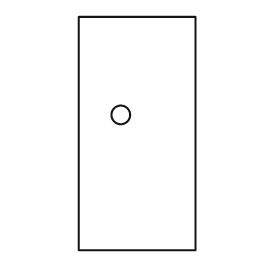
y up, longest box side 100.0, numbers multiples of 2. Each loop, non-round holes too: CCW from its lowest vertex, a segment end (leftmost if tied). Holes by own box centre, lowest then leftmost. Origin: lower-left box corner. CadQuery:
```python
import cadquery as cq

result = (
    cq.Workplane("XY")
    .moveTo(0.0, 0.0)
    .lineTo(50.0, 0.0)
    .lineTo(50.0, 100.0)
    .lineTo(0.0, 100.0)
    .close()
    .moveTo(18.0, 58.0)
    .circle(4.0)
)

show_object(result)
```